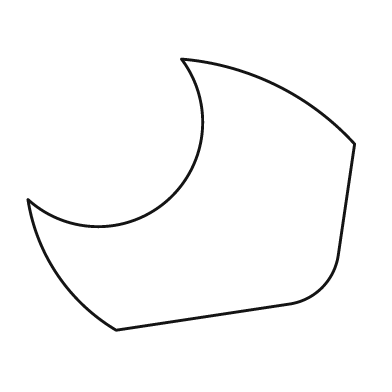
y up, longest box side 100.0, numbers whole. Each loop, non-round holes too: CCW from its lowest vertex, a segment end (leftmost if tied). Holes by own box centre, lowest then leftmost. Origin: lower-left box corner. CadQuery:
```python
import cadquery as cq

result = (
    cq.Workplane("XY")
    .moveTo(27.0, 0.0)
    .lineTo(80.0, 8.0)
    .threePointArc((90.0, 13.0), (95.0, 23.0))
    .lineTo(100.0, 57.0)
    .threePointArc((76.0, 75.0), (47.0, 83.0))
    .threePointArc((43.0, 40.0), (0.0, 40.0))
    .threePointArc((9.0, 17.0), (27.0, 0.0))
    .close()
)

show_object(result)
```